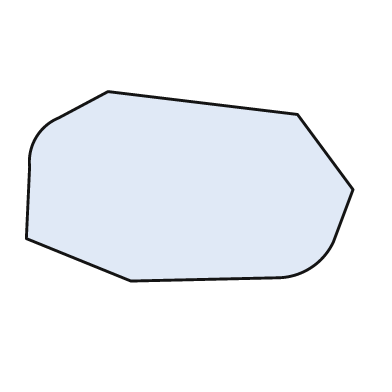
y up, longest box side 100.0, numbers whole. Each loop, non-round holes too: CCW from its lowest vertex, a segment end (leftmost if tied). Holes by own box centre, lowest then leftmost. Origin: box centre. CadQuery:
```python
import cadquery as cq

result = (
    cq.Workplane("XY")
    .moveTo(-18.0, -29.0)
    .lineTo(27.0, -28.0)
    .threePointArc((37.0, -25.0), (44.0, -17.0))
    .lineTo(50.0, -1.0)
    .lineTo(33.0, 22.0)
    .lineTo(-25.0, 29.0)
    .lineTo(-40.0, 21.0)
    .threePointArc((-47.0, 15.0), (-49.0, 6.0))
    .lineTo(-50.0, -16.0)
    .close()
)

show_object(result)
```